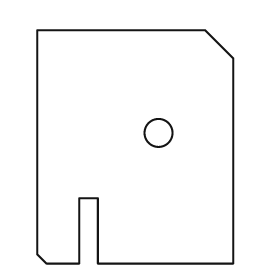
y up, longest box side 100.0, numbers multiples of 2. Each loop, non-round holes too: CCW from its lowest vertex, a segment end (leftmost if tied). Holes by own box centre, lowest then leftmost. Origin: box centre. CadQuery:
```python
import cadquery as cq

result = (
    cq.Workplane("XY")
    .moveTo(-38.0, -50.0)
    .lineTo(-24.0, -50.0)
    .lineTo(-24.0, -22.0)
    .lineTo(-16.0, -22.0)
    .lineTo(-16.0, -50.0)
    .lineTo(42.0, -50.0)
    .lineTo(42.0, 38.0)
    .lineTo(30.0, 50.0)
    .lineTo(-42.0, 50.0)
    .lineTo(-42.0, -46.0)
    .close()
    .moveTo(10.0, 6.0)
    .circle(6.0)
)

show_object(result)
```